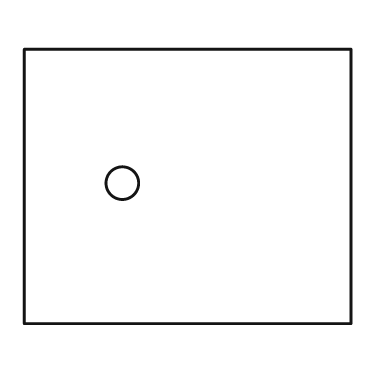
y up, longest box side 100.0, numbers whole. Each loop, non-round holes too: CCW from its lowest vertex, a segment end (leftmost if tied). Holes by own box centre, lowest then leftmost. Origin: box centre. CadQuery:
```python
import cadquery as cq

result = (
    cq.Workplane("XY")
    .moveTo(-50.0, -42.0)
    .lineTo(50.0, -42.0)
    .lineTo(50.0, 42.0)
    .lineTo(-50.0, 42.0)
    .close()
    .moveTo(-20.0, 1.0)
    .circle(5.0)
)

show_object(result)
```